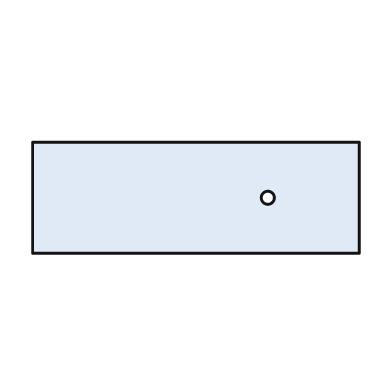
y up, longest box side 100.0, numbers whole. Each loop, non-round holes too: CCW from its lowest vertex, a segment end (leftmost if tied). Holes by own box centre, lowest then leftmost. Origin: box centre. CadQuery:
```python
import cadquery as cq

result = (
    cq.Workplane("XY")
    .moveTo(-50.0, -17.0)
    .lineTo(50.0, -17.0)
    .lineTo(50.0, 17.0)
    .lineTo(-50.0, 17.0)
    .close()
    .moveTo(22.0, 0.0)
    .circle(2.0)
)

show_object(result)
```